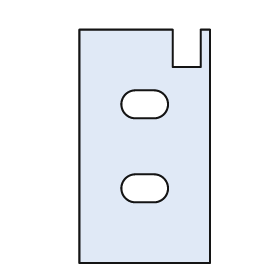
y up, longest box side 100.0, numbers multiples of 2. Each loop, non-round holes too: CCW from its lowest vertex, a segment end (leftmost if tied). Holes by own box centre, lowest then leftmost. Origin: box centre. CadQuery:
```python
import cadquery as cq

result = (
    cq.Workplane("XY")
    .moveTo(-28.0, -50.0)
    .lineTo(28.0, -50.0)
    .lineTo(28.0, 50.0)
    .lineTo(24.0, 50.0)
    .lineTo(24.0, 34.0)
    .lineTo(12.0, 34.0)
    .lineTo(12.0, 50.0)
    .lineTo(-28.0, 50.0)
    .close()
    .moveTo(-4.0, -24.0)
    .lineTo(4.0, -24.0)
    .threePointArc((10.0, -18.0), (4.0, -12.0))
    .lineTo(-4.0, -12.0)
    .threePointArc((-10.0, -18.0), (-4.0, -24.0))
    .close()
    .moveTo(-4.0, 12.0)
    .lineTo(4.0, 12.0)
    .threePointArc((10.0, 18.0), (4.0, 24.0))
    .lineTo(-4.0, 24.0)
    .threePointArc((-10.0, 18.0), (-4.0, 12.0))
    .close()
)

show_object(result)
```